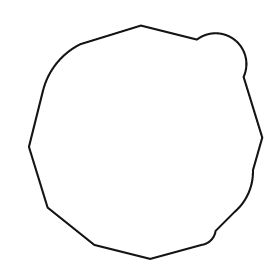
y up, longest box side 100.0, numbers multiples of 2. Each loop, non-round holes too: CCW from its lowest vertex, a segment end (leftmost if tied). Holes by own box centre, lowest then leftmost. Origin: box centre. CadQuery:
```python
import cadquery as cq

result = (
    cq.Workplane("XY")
    .moveTo(2.0, -50.0)
    .lineTo(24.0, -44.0)
    .threePointArc((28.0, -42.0), (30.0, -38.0))
    .lineTo(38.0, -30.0)
    .threePointArc((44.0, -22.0), (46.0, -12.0))
    .lineTo(50.0, 2.0)
    .lineTo(42.0, 28.0)
    .threePointArc((38.0, 44.0), (22.0, 44.0))
    .lineTo(-2.0, 50.0)
    .lineTo(-28.0, 42.0)
    .threePointArc((-38.0, 34.0), (-44.0, 22.0))
    .lineTo(-50.0, -2.0)
    .lineTo(-42.0, -28.0)
    .lineTo(-22.0, -44.0)
    .close()
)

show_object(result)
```